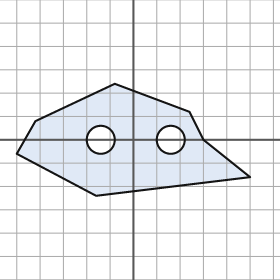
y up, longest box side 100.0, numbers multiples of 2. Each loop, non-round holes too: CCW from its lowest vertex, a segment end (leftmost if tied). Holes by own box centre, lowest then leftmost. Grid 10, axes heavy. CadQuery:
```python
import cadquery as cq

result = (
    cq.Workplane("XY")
    .moveTo(-16.0, -24.0)
    .lineTo(50.0, -16.0)
    .lineTo(30.0, 0.0)
    .lineTo(24.0, 12.0)
    .lineTo(-8.0, 24.0)
    .lineTo(-42.0, 8.0)
    .lineTo(-50.0, -6.0)
    .close()
    .moveTo(-14.0, 0.0)
    .circle(6.0)
    .moveTo(16.0, 0.0)
    .circle(6.0)
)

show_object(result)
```